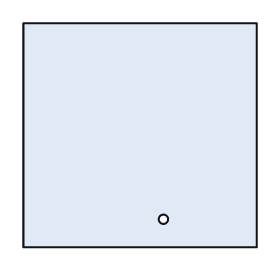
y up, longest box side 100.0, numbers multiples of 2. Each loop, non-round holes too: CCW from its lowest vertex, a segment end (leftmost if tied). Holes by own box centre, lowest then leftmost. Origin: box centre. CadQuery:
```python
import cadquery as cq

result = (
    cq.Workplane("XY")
    .moveTo(-50.0, -48.0)
    .lineTo(50.0, -48.0)
    .lineTo(50.0, 48.0)
    .lineTo(-50.0, 48.0)
    .close()
    .moveTo(10.0, -36.0)
    .circle(2.0)
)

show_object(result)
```